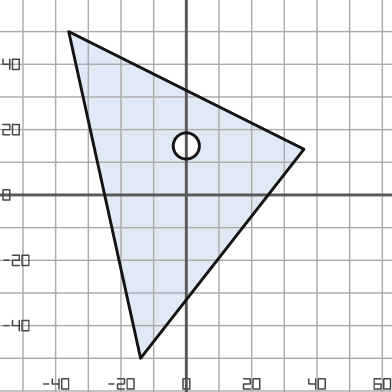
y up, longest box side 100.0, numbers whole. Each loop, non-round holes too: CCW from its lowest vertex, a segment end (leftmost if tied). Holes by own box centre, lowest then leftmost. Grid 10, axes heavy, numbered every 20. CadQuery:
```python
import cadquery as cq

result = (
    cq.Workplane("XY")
    .moveTo(-14.0, -50.0)
    .lineTo(36.0, 14.0)
    .lineTo(-36.0, 50.0)
    .close()
    .moveTo(0.0, 15.0)
    .circle(4.0)
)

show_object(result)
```